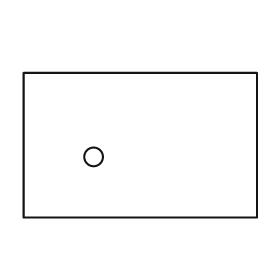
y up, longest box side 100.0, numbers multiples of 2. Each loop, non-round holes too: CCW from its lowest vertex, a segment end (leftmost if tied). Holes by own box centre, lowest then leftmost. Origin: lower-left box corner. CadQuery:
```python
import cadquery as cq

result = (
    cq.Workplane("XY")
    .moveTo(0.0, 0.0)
    .lineTo(100.0, 0.0)
    .lineTo(100.0, 62.0)
    .lineTo(0.0, 62.0)
    .close()
    .moveTo(30.0, 26.0)
    .circle(4.0)
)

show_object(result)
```